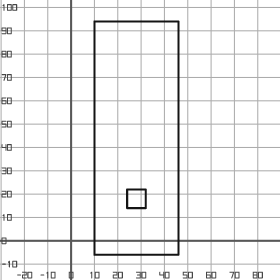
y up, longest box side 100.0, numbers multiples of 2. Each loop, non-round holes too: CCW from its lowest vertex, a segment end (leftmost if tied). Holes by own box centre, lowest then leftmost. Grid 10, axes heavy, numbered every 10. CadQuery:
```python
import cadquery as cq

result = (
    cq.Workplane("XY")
    .moveTo(10.0, -6.0)
    .lineTo(46.0, -6.0)
    .lineTo(46.0, 94.0)
    .lineTo(10.0, 94.0)
    .close()
    .moveTo(24.0, 14.0)
    .lineTo(32.0, 14.0)
    .lineTo(32.0, 22.0)
    .lineTo(24.0, 22.0)
    .close()
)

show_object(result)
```